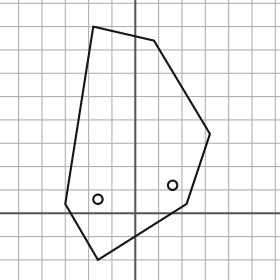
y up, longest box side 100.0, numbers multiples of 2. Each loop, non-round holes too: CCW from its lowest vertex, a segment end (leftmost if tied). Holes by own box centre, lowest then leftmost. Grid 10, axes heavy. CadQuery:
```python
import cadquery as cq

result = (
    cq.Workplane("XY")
    .moveTo(-16.0, -20.0)
    .lineTo(22.0, 4.0)
    .lineTo(32.0, 34.0)
    .lineTo(8.0, 74.0)
    .lineTo(-18.0, 80.0)
    .lineTo(-30.0, 4.0)
    .close()
    .moveTo(-16.0, 6.0)
    .circle(2.0)
    .moveTo(16.0, 12.0)
    .circle(2.0)
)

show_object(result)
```